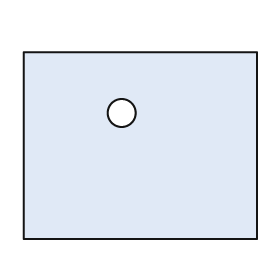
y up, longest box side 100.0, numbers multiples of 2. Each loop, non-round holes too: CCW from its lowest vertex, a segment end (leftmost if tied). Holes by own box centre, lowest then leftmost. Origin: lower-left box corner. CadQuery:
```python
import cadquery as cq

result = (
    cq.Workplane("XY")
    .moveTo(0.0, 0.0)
    .lineTo(100.0, 0.0)
    .lineTo(100.0, 80.0)
    .lineTo(0.0, 80.0)
    .close()
    .moveTo(42.0, 54.0)
    .circle(6.0)
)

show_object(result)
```